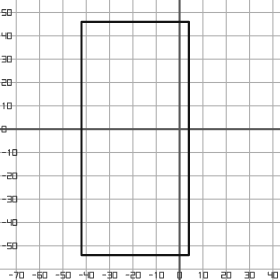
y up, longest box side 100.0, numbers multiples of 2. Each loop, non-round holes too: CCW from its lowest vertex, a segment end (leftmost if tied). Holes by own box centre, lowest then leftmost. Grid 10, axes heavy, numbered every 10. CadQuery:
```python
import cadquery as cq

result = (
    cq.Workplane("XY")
    .moveTo(-42.0, -54.0)
    .lineTo(4.0, -54.0)
    .lineTo(4.0, 46.0)
    .lineTo(-42.0, 46.0)
    .close()
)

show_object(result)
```